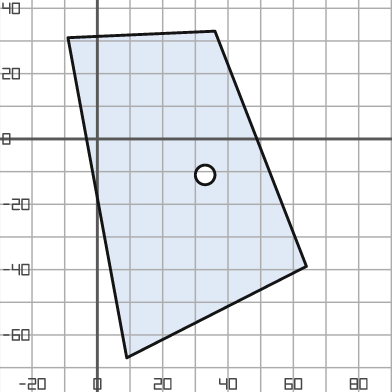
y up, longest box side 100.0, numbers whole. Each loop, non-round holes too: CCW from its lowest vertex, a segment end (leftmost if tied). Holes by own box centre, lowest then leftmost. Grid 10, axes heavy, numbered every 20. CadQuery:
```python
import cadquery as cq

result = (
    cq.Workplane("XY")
    .moveTo(9.0, -67.0)
    .lineTo(64.0, -39.0)
    .lineTo(36.0, 33.0)
    .lineTo(-9.0, 31.0)
    .close()
    .moveTo(33.0, -11.0)
    .circle(3.0)
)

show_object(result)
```